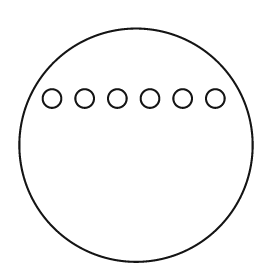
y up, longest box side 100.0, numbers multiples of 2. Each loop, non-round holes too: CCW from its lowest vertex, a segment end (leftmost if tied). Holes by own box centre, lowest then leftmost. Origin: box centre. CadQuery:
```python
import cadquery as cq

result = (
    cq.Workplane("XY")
    .moveTo(0.0, 0.0)
    .circle(50.0)
    .moveTo(-36.0, 20.0)
    .circle(4.0)
    .moveTo(-22.0, 20.0)
    .circle(4.0)
    .moveTo(-8.0, 20.0)
    .circle(4.0)
    .moveTo(6.0, 20.0)
    .circle(4.0)
    .moveTo(20.0, 20.0)
    .circle(4.0)
    .moveTo(34.0, 20.0)
    .circle(4.0)
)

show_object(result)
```